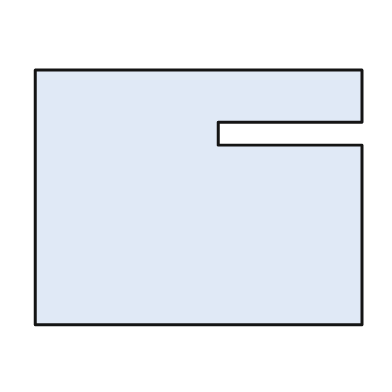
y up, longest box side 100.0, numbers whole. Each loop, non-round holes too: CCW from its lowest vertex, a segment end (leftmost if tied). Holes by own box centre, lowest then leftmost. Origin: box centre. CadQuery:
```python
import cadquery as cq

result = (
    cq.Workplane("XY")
    .moveTo(-50.0, -39.0)
    .lineTo(50.0, -39.0)
    .lineTo(50.0, 16.0)
    .lineTo(6.0, 16.0)
    .lineTo(6.0, 23.0)
    .lineTo(50.0, 23.0)
    .lineTo(50.0, 39.0)
    .lineTo(-50.0, 39.0)
    .close()
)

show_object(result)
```